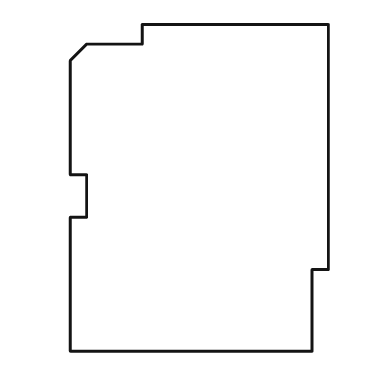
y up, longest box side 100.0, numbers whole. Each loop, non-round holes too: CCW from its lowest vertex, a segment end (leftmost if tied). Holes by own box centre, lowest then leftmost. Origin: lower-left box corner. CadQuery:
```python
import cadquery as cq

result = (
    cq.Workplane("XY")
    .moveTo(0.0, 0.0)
    .lineTo(74.0, 0.0)
    .lineTo(74.0, 25.0)
    .lineTo(79.0, 25.0)
    .lineTo(79.0, 100.0)
    .lineTo(22.0, 100.0)
    .lineTo(22.0, 94.0)
    .lineTo(5.0, 94.0)
    .lineTo(0.0, 89.0)
    .lineTo(0.0, 54.0)
    .lineTo(5.0, 54.0)
    .lineTo(5.0, 41.0)
    .lineTo(0.0, 41.0)
    .close()
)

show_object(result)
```